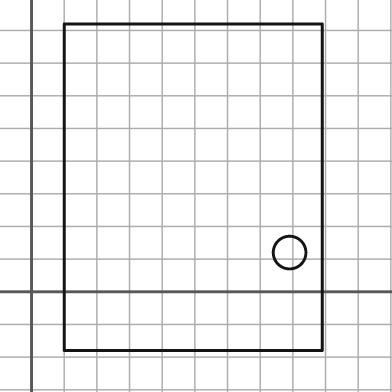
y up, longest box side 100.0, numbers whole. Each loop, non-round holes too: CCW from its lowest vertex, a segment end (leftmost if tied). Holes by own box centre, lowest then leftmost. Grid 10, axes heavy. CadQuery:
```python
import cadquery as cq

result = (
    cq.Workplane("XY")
    .moveTo(10.0, -18.0)
    .lineTo(89.0, -18.0)
    .lineTo(89.0, 82.0)
    .lineTo(10.0, 82.0)
    .close()
    .moveTo(79.0, 12.0)
    .circle(5.0)
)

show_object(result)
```